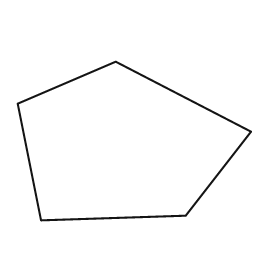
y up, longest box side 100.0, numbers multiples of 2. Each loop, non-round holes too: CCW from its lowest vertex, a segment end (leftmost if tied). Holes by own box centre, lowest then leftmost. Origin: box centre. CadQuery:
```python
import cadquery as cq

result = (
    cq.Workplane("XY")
    .moveTo(-40.0, -34.0)
    .lineTo(22.0, -32.0)
    .lineTo(50.0, 4.0)
    .lineTo(-8.0, 34.0)
    .lineTo(-50.0, 16.0)
    .close()
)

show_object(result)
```